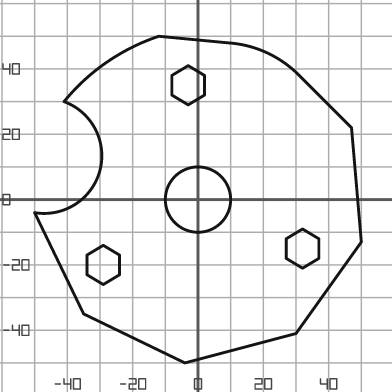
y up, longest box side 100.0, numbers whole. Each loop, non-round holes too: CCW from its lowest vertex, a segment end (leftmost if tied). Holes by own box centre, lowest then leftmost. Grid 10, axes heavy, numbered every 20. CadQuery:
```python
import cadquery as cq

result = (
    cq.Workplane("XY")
    .moveTo(-4.0, -50.0)
    .lineTo(30.0, -41.0)
    .lineTo(50.0, -13.0)
    .lineTo(47.0, 22.0)
    .lineTo(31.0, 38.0)
    .threePointArc((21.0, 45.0), (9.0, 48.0))
    .lineTo(-12.0, 50.0)
    .threePointArc((-28.0, 42.0), (-41.0, 30.0))
    .threePointArc((-30.0, 9.0), (-50.0, -4.0))
    .lineTo(-35.0, -35.0)
    .close()
    .moveTo(-29.0, -26.0)
    .lineTo(-24.0, -23.0)
    .lineTo(-24.0, -17.0)
    .lineTo(-29.0, -14.0)
    .lineTo(-34.0, -17.0)
    .lineTo(-34.0, -23.0)
    .close()
    .moveTo(32.0, -21.0)
    .lineTo(37.0, -18.0)
    .lineTo(37.0, -12.0)
    .lineTo(32.0, -9.0)
    .lineTo(27.0, -12.0)
    .lineTo(27.0, -18.0)
    .close()
    .moveTo(0.0, 0.0)
    .circle(10.0)
    .moveTo(-3.0, 29.0)
    .lineTo(2.0, 32.0)
    .lineTo(2.0, 38.0)
    .lineTo(-3.0, 41.0)
    .lineTo(-8.0, 38.0)
    .lineTo(-8.0, 32.0)
    .close()
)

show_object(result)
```